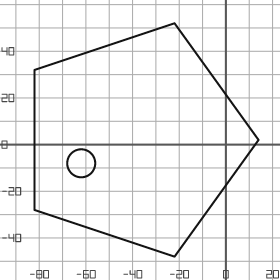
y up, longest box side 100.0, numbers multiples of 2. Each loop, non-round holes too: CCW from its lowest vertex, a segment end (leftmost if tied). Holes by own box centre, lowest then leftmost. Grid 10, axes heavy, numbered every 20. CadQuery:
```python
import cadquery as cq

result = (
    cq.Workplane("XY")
    .moveTo(-22.0, -48.0)
    .lineTo(14.0, 2.0)
    .lineTo(-22.0, 52.0)
    .lineTo(-82.0, 32.0)
    .lineTo(-82.0, -28.0)
    .close()
    .moveTo(-62.0, -8.0)
    .circle(6.0)
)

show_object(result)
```